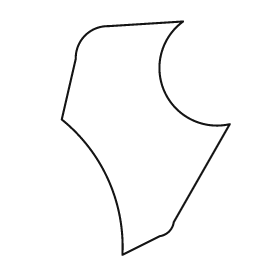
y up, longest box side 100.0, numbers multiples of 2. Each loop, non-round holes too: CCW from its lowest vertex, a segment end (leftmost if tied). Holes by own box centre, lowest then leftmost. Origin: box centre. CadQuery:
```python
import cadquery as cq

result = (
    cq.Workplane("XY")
    .moveTo(-10.0, -50.0)
    .lineTo(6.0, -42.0)
    .threePointArc((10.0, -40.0), (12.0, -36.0))
    .lineTo(36.0, 6.0)
    .threePointArc((8.0, 20.0), (16.0, 50.0))
    .lineTo(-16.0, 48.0)
    .threePointArc((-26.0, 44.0), (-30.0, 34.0))
    .lineTo(-36.0, 8.0)
    .threePointArc((-16.0, -18.0), (-10.0, -50.0))
    .close()
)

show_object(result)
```